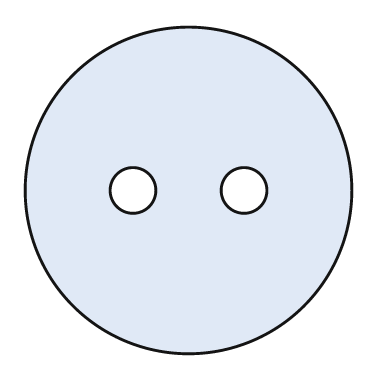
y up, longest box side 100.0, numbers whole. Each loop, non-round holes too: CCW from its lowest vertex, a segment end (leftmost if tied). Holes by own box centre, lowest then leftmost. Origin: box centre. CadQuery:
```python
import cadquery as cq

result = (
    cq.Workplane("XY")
    .moveTo(0.0, 0.0)
    .circle(50.0)
    .moveTo(-17.0, 0.0)
    .circle(7.0)
    .moveTo(17.0, 0.0)
    .circle(7.0)
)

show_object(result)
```